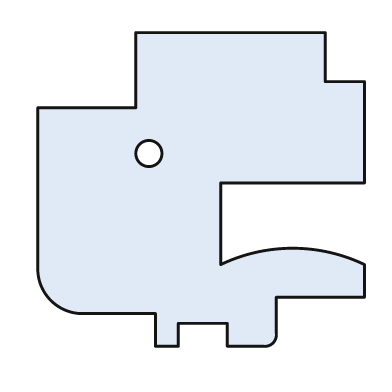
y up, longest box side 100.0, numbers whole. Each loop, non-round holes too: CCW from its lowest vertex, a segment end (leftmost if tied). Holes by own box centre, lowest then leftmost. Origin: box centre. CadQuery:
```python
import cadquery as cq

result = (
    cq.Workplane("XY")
    .moveTo(-14.0, -48.0)
    .lineTo(-7.0, -48.0)
    .lineTo(-7.0, -41.0)
    .lineTo(8.0, -41.0)
    .lineTo(8.0, -48.0)
    .lineTo(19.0, -48.0)
    .threePointArc((22.0, -47.0), (23.0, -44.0))
    .lineTo(23.0, -33.0)
    .lineTo(50.0, -33.0)
    .lineTo(50.0, -23.0)
    .threePointArc((28.0, -18.0), (6.0, -23.0))
    .lineTo(6.0, 2.0)
    .lineTo(50.0, 2.0)
    .lineTo(50.0, 33.0)
    .lineTo(38.0, 33.0)
    .lineTo(38.0, 48.0)
    .lineTo(-20.0, 48.0)
    .lineTo(-20.0, 25.0)
    .lineTo(-50.0, 25.0)
    .lineTo(-50.0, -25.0)
    .threePointArc((-46.0, -34.0), (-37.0, -38.0))
    .lineTo(-14.0, -38.0)
    .close()
    .moveTo(-16.0, 11.0)
    .circle(4.0)
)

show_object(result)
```